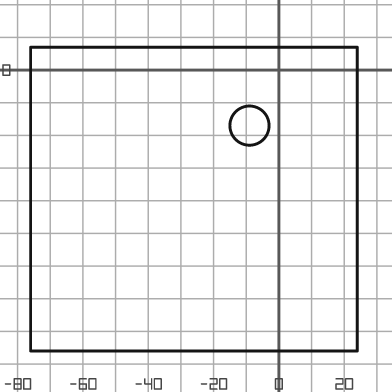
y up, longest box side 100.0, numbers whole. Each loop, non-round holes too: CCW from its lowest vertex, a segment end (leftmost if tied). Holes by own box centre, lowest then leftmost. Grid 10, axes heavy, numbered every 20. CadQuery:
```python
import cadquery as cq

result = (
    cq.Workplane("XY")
    .moveTo(-76.0, -86.0)
    .lineTo(24.0, -86.0)
    .lineTo(24.0, 7.0)
    .lineTo(-76.0, 7.0)
    .close()
    .moveTo(-9.0, -17.0)
    .circle(6.0)
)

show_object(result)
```